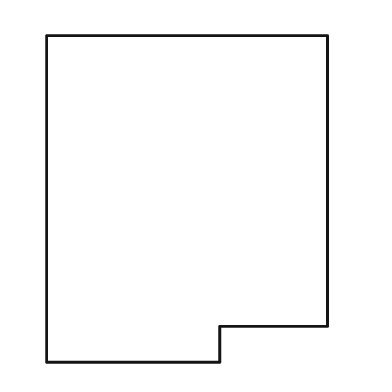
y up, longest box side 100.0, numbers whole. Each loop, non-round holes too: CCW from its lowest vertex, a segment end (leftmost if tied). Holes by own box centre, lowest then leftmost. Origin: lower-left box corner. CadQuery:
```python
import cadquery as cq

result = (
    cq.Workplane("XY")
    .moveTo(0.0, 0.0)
    .lineTo(53.0, 0.0)
    .lineTo(53.0, 11.0)
    .lineTo(86.0, 11.0)
    .lineTo(86.0, 100.0)
    .lineTo(0.0, 100.0)
    .close()
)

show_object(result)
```